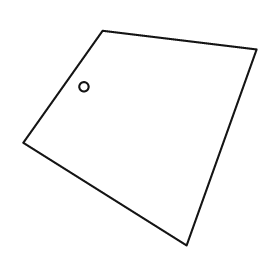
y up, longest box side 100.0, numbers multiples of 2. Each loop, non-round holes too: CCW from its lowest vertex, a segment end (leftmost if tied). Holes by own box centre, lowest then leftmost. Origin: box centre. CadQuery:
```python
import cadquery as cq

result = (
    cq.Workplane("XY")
    .moveTo(20.0, -46.0)
    .lineTo(50.0, 38.0)
    .lineTo(-16.0, 46.0)
    .lineTo(-50.0, -2.0)
    .close()
    .moveTo(-24.0, 22.0)
    .circle(2.0)
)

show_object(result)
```